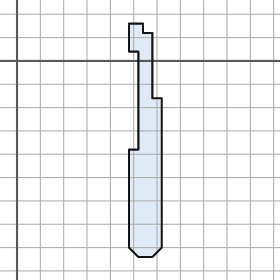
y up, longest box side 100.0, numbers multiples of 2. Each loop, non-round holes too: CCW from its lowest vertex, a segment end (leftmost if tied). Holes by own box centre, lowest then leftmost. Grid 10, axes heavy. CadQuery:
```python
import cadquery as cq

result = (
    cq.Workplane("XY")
    .moveTo(52.0, -84.0)
    .lineTo(58.0, -84.0)
    .lineTo(62.0, -80.0)
    .lineTo(62.0, -16.0)
    .lineTo(58.0, -16.0)
    .lineTo(58.0, 12.0)
    .lineTo(54.0, 12.0)
    .lineTo(54.0, 16.0)
    .lineTo(48.0, 16.0)
    .lineTo(48.0, 4.0)
    .lineTo(52.0, 4.0)
    .lineTo(52.0, -38.0)
    .lineTo(48.0, -38.0)
    .lineTo(48.0, -80.0)
    .close()
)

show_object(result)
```